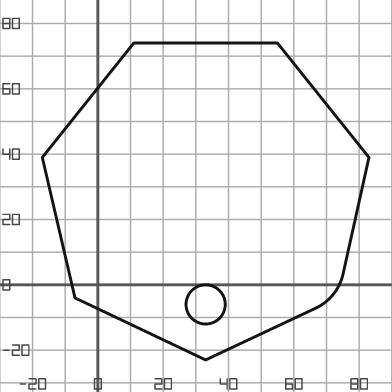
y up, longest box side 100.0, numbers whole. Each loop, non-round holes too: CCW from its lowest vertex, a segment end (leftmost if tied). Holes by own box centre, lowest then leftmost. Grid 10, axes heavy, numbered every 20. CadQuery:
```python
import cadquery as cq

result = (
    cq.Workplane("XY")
    .moveTo(33.0, -23.0)
    .lineTo(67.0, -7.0)
    .threePointArc((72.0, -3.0), (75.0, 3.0))
    .lineTo(83.0, 39.0)
    .lineTo(55.0, 74.0)
    .lineTo(11.0, 74.0)
    .lineTo(-17.0, 39.0)
    .lineTo(-7.0, -4.0)
    .close()
    .moveTo(33.0, -6.0)
    .circle(6.0)
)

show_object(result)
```